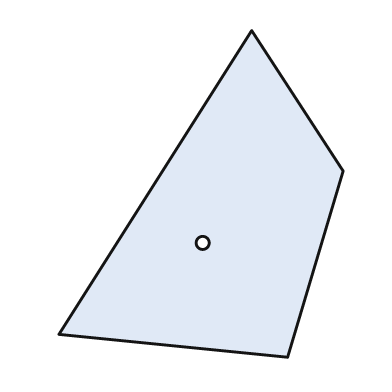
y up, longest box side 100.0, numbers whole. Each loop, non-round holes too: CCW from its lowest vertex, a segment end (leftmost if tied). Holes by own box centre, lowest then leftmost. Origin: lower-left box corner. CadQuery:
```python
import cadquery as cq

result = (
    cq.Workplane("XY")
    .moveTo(70.0, 0.0)
    .lineTo(87.0, 57.0)
    .lineTo(59.0, 100.0)
    .lineTo(0.0, 7.0)
    .close()
    .moveTo(44.0, 35.0)
    .circle(2.0)
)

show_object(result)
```